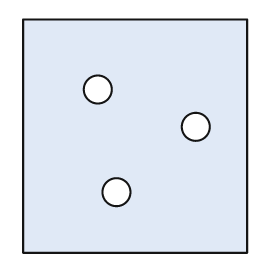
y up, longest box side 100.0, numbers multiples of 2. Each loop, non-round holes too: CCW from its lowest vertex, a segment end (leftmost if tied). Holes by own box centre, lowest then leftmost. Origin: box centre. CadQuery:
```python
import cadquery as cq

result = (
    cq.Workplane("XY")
    .moveTo(-48.0, -50.0)
    .lineTo(48.0, -50.0)
    .lineTo(48.0, 50.0)
    .lineTo(-48.0, 50.0)
    .close()
    .moveTo(-8.0, -24.0)
    .circle(6.0)
    .moveTo(26.0, 4.0)
    .circle(6.0)
    .moveTo(-16.0, 20.0)
    .circle(6.0)
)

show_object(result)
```